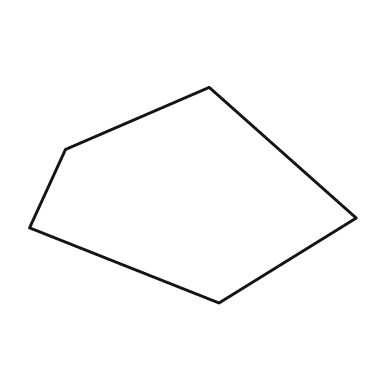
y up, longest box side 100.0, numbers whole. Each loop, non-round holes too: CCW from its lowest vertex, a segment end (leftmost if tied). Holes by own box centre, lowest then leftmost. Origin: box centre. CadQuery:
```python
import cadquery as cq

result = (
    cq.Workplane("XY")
    .moveTo(8.0, -33.0)
    .lineTo(50.0, -7.0)
    .lineTo(5.0, 33.0)
    .lineTo(-39.0, 14.0)
    .lineTo(-50.0, -10.0)
    .close()
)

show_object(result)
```